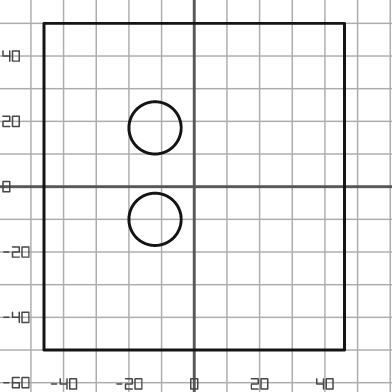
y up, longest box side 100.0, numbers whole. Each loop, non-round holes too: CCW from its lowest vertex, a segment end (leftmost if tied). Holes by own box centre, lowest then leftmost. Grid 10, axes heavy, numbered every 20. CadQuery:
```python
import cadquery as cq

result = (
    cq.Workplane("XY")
    .moveTo(-46.0, -50.0)
    .lineTo(46.0, -50.0)
    .lineTo(46.0, 50.0)
    .lineTo(-46.0, 50.0)
    .close()
    .moveTo(-12.0, -10.0)
    .circle(8.0)
    .moveTo(-12.0, 18.0)
    .circle(8.0)
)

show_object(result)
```